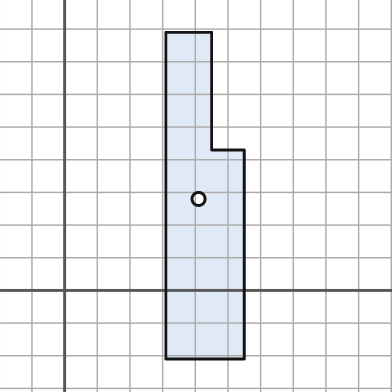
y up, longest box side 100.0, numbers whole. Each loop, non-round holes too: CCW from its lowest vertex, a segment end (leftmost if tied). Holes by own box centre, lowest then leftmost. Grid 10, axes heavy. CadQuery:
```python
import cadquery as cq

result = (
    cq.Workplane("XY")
    .moveTo(31.0, -21.0)
    .lineTo(55.0, -21.0)
    .lineTo(55.0, 43.0)
    .lineTo(45.0, 43.0)
    .lineTo(45.0, 79.0)
    .lineTo(31.0, 79.0)
    .close()
    .moveTo(41.0, 28.0)
    .circle(2.0)
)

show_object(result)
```